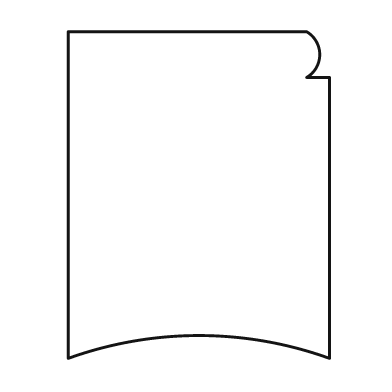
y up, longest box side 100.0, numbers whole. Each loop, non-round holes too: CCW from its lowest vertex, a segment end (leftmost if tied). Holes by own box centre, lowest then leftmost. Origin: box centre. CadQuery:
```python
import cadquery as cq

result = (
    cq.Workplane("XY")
    .moveTo(-40.0, -50.0)
    .threePointArc((0.0, -43.0), (40.0, -50.0))
    .lineTo(40.0, 36.0)
    .lineTo(33.0, 36.0)
    .threePointArc((37.0, 43.0), (33.0, 50.0))
    .lineTo(-40.0, 50.0)
    .close()
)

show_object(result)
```